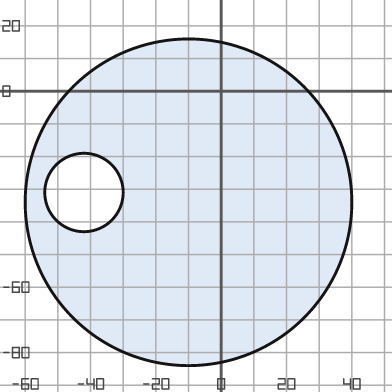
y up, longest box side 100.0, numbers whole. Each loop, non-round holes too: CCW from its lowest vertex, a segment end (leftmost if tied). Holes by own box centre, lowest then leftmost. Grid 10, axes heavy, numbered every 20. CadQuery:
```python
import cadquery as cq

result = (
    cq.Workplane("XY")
    .moveTo(-10.0, -34.0)
    .circle(50.0)
    .moveTo(-42.0, -31.0)
    .circle(12.0)
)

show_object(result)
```